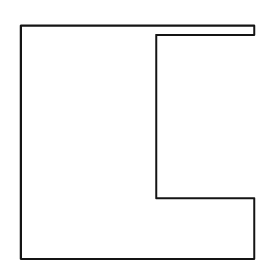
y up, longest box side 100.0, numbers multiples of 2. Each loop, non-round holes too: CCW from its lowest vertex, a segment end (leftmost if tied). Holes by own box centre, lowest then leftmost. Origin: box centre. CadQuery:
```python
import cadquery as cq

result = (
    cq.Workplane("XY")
    .moveTo(-50.0, -50.0)
    .lineTo(50.0, -50.0)
    .lineTo(50.0, -24.0)
    .lineTo(8.0, -24.0)
    .lineTo(8.0, 46.0)
    .lineTo(50.0, 46.0)
    .lineTo(50.0, 50.0)
    .lineTo(-50.0, 50.0)
    .close()
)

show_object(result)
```